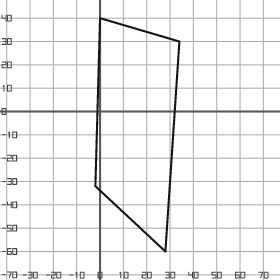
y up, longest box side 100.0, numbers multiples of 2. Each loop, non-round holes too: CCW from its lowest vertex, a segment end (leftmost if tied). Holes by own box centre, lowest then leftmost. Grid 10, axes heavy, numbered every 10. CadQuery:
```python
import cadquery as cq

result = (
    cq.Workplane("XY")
    .moveTo(28.0, -60.0)
    .lineTo(34.0, 30.0)
    .lineTo(0.0, 40.0)
    .lineTo(-2.0, -32.0)
    .close()
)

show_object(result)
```